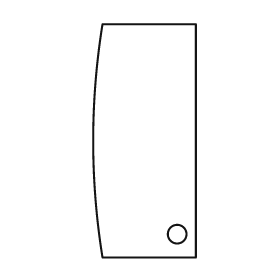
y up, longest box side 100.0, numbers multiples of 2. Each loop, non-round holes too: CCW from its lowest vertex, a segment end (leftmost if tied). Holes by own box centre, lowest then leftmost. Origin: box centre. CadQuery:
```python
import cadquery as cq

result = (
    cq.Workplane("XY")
    .moveTo(-18.0, -50.0)
    .lineTo(22.0, -50.0)
    .lineTo(22.0, 50.0)
    .lineTo(-18.0, 50.0)
    .threePointArc((-22.0, 0.0), (-18.0, -50.0))
    .close()
    .moveTo(14.0, -40.0)
    .circle(4.0)
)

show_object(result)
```